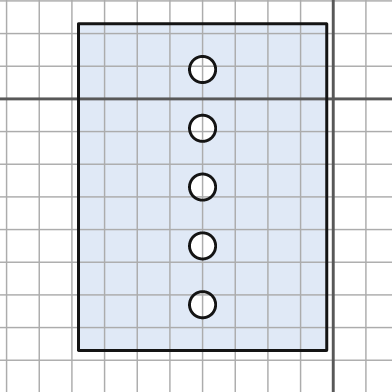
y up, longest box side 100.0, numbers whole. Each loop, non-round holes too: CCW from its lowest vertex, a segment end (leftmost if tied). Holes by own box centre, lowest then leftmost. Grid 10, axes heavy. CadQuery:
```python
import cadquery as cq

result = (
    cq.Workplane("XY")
    .moveTo(-78.0, -77.0)
    .lineTo(-2.0, -77.0)
    .lineTo(-2.0, 23.0)
    .lineTo(-78.0, 23.0)
    .close()
    .moveTo(-40.0, -63.0)
    .circle(4.0)
    .moveTo(-40.0, -45.0)
    .circle(4.0)
    .moveTo(-40.0, -27.0)
    .circle(4.0)
    .moveTo(-40.0, -9.0)
    .circle(4.0)
    .moveTo(-40.0, 9.0)
    .circle(4.0)
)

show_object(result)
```